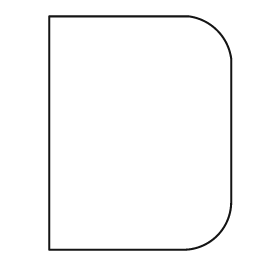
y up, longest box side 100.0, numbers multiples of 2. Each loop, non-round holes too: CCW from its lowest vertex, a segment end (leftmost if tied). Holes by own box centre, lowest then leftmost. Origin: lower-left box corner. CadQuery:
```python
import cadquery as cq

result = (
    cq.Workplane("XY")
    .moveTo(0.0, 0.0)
    .lineTo(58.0, 0.0)
    .threePointArc((72.0, 6.0), (78.0, 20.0))
    .lineTo(78.0, 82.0)
    .threePointArc((72.0, 94.0), (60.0, 100.0))
    .lineTo(0.0, 100.0)
    .close()
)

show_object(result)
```